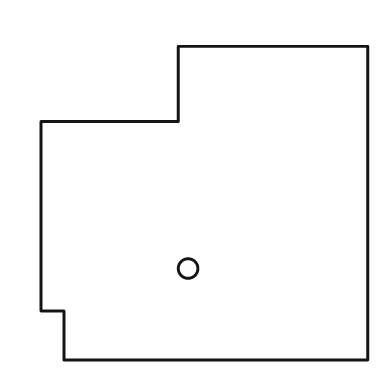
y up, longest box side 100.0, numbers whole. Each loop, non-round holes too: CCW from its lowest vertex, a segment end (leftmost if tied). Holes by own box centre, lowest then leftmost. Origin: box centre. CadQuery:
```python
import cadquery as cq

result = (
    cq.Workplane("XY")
    .moveTo(-43.0, -48.0)
    .lineTo(50.0, -48.0)
    .lineTo(50.0, 48.0)
    .lineTo(-8.0, 48.0)
    .lineTo(-8.0, 25.0)
    .lineTo(-50.0, 25.0)
    .lineTo(-50.0, -33.0)
    .lineTo(-43.0, -33.0)
    .close()
    .moveTo(-5.0, -20.0)
    .circle(3.0)
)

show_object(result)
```